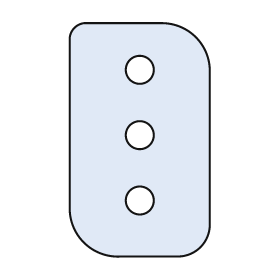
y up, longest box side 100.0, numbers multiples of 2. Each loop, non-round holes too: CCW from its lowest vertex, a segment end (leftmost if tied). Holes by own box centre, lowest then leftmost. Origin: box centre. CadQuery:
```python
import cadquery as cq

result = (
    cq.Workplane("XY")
    .moveTo(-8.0, -50.0)
    .lineTo(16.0, -50.0)
    .threePointArc((26.0, -46.0), (30.0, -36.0))
    .lineTo(30.0, 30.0)
    .threePointArc((24.0, 44.0), (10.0, 50.0))
    .lineTo(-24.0, 50.0)
    .threePointArc((-28.0, 48.0), (-30.0, 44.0))
    .lineTo(-30.0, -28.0)
    .threePointArc((-24.0, -44.0), (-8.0, -50.0))
    .close()
    .moveTo(0.0, -26.0)
    .circle(6.0)
    .moveTo(0.0, 2.0)
    .circle(6.0)
    .moveTo(0.0, 30.0)
    .circle(6.0)
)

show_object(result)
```